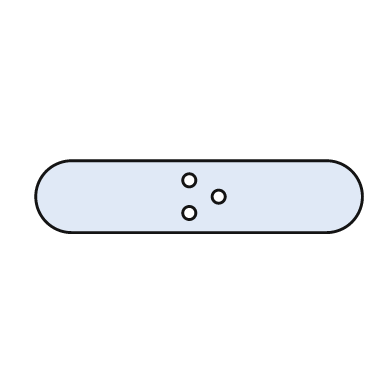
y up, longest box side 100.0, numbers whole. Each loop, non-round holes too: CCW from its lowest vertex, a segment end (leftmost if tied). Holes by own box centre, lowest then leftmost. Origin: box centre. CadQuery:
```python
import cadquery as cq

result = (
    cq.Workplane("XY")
    .moveTo(-39.0, -11.0)
    .lineTo(39.0, -11.0)
    .threePointArc((50.0, 0.0), (39.0, 11.0))
    .lineTo(-39.0, 11.0)
    .threePointArc((-50.0, 0.0), (-39.0, -11.0))
    .close()
    .moveTo(-3.0, -5.0)
    .circle(2.0)
    .moveTo(6.0, 0.0)
    .circle(2.0)
    .moveTo(-3.0, 5.0)
    .circle(2.0)
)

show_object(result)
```